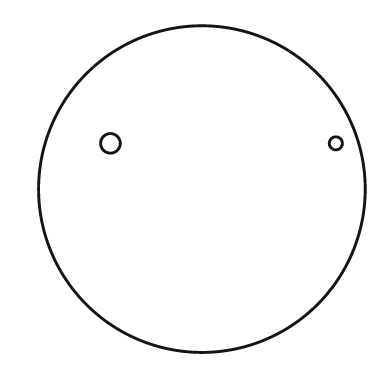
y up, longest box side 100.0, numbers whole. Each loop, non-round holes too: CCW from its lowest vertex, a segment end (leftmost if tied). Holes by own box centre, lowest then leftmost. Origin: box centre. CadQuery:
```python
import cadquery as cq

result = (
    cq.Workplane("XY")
    .moveTo(0.0, 0.0)
    .circle(50.0)
    .moveTo(-28.0, 14.0)
    .circle(3.0)
    .moveTo(41.0, 14.0)
    .circle(2.0)
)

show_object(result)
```